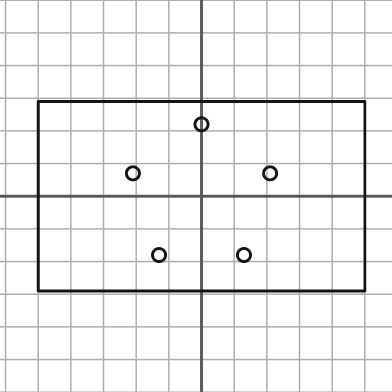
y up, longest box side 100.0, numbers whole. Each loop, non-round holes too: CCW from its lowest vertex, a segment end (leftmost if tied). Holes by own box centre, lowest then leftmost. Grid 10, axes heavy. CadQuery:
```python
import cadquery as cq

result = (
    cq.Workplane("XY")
    .moveTo(-50.0, -29.0)
    .lineTo(50.0, -29.0)
    .lineTo(50.0, 29.0)
    .lineTo(-50.0, 29.0)
    .close()
    .moveTo(-13.0, -18.0)
    .circle(2.0)
    .moveTo(13.0, -18.0)
    .circle(2.0)
    .moveTo(-21.0, 7.0)
    .circle(2.0)
    .moveTo(21.0, 7.0)
    .circle(2.0)
    .moveTo(0.0, 22.0)
    .circle(2.0)
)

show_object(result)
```